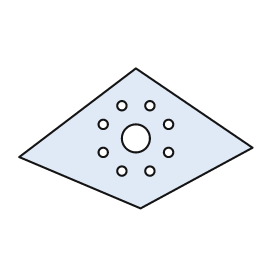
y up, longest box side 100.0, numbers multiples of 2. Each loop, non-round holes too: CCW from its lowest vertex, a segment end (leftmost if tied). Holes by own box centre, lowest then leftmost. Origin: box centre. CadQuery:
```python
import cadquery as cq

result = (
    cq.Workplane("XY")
    .moveTo(2.0, -30.0)
    .lineTo(50.0, -4.0)
    .lineTo(0.0, 30.0)
    .lineTo(-50.0, -8.0)
    .close()
    .moveTo(-6.0, -14.0)
    .circle(2.0)
    .moveTo(6.0, -14.0)
    .circle(2.0)
    .moveTo(-14.0, -6.0)
    .circle(2.0)
    .moveTo(14.0, -6.0)
    .circle(2.0)
    .moveTo(0.0, 0.0)
    .circle(6.0)
    .moveTo(-14.0, 6.0)
    .circle(2.0)
    .moveTo(14.0, 6.0)
    .circle(2.0)
    .moveTo(-6.0, 14.0)
    .circle(2.0)
    .moveTo(6.0, 14.0)
    .circle(2.0)
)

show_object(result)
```